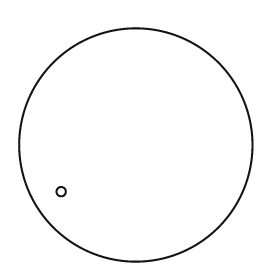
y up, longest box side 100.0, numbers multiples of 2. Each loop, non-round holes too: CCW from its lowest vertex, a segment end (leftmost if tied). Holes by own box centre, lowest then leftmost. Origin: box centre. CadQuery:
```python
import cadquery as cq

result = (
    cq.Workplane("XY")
    .moveTo(0.0, 0.0)
    .circle(50.0)
    .moveTo(-32.0, -20.0)
    .circle(2.0)
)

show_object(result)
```